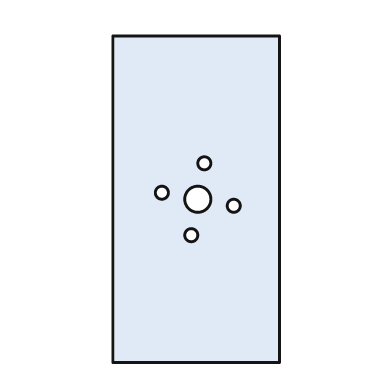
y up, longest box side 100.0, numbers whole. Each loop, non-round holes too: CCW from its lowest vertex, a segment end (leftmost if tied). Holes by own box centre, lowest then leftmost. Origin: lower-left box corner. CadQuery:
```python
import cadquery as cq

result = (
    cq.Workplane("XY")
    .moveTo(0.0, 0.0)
    .lineTo(51.0, 0.0)
    .lineTo(51.0, 100.0)
    .lineTo(0.0, 100.0)
    .close()
    .moveTo(24.0, 39.0)
    .circle(2.0)
    .moveTo(37.0, 48.0)
    .circle(2.0)
    .moveTo(26.0, 50.0)
    .circle(4.0)
    .moveTo(15.0, 52.0)
    .circle(2.0)
    .moveTo(28.0, 61.0)
    .circle(2.0)
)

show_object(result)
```